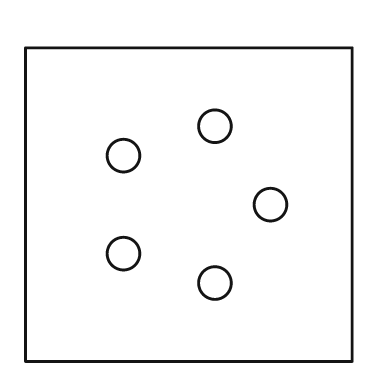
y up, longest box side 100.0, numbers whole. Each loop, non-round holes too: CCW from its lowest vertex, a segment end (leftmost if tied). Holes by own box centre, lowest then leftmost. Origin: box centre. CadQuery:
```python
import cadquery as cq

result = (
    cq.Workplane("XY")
    .moveTo(-50.0, -48.0)
    .lineTo(50.0, -48.0)
    .lineTo(50.0, 48.0)
    .lineTo(-50.0, 48.0)
    .close()
    .moveTo(8.0, -24.0)
    .circle(5.0)
    .moveTo(-20.0, -15.0)
    .circle(5.0)
    .moveTo(25.0, 0.0)
    .circle(5.0)
    .moveTo(-20.0, 15.0)
    .circle(5.0)
    .moveTo(8.0, 24.0)
    .circle(5.0)
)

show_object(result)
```